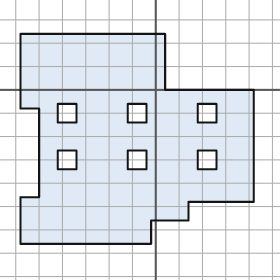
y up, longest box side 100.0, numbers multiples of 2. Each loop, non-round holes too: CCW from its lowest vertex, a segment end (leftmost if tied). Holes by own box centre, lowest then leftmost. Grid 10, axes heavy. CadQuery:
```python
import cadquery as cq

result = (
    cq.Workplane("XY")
    .moveTo(-58.0, -66.0)
    .lineTo(-2.0, -66.0)
    .lineTo(-2.0, -56.0)
    .lineTo(14.0, -56.0)
    .lineTo(14.0, -48.0)
    .lineTo(42.0, -48.0)
    .lineTo(42.0, 0.0)
    .lineTo(4.0, 0.0)
    .lineTo(4.0, 24.0)
    .lineTo(-58.0, 24.0)
    .lineTo(-58.0, -8.0)
    .lineTo(-50.0, -8.0)
    .lineTo(-50.0, -46.0)
    .lineTo(-58.0, -46.0)
    .close()
    .moveTo(-42.0, -34.0)
    .lineTo(-34.0, -34.0)
    .lineTo(-34.0, -26.0)
    .lineTo(-42.0, -26.0)
    .close()
    .moveTo(-12.0, -34.0)
    .lineTo(-4.0, -34.0)
    .lineTo(-4.0, -26.0)
    .lineTo(-12.0, -26.0)
    .close()
    .moveTo(18.0, -34.0)
    .lineTo(26.0, -34.0)
    .lineTo(26.0, -26.0)
    .lineTo(18.0, -26.0)
    .close()
    .moveTo(-42.0, -14.0)
    .lineTo(-34.0, -14.0)
    .lineTo(-34.0, -6.0)
    .lineTo(-42.0, -6.0)
    .close()
    .moveTo(-12.0, -14.0)
    .lineTo(-4.0, -14.0)
    .lineTo(-4.0, -6.0)
    .lineTo(-12.0, -6.0)
    .close()
    .moveTo(18.0, -14.0)
    .lineTo(26.0, -14.0)
    .lineTo(26.0, -6.0)
    .lineTo(18.0, -6.0)
    .close()
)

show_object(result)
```